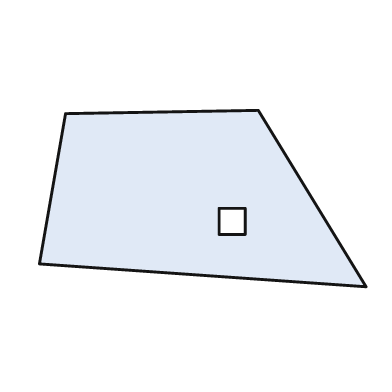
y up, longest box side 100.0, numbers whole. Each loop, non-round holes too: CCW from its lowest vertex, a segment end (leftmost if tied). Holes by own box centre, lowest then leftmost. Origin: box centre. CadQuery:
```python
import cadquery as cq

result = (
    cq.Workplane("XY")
    .moveTo(50.0, -27.0)
    .lineTo(17.0, 27.0)
    .lineTo(-42.0, 26.0)
    .lineTo(-50.0, -20.0)
    .close()
    .moveTo(5.0, -11.0)
    .lineTo(13.0, -11.0)
    .lineTo(13.0, -3.0)
    .lineTo(5.0, -3.0)
    .close()
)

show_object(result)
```